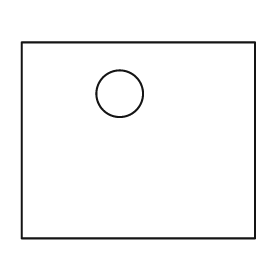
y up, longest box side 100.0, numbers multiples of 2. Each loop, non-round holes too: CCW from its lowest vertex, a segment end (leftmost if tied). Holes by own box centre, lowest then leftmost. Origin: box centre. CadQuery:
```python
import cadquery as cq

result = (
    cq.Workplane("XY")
    .moveTo(-50.0, -42.0)
    .lineTo(50.0, -42.0)
    .lineTo(50.0, 42.0)
    .lineTo(-50.0, 42.0)
    .close()
    .moveTo(-8.0, 20.0)
    .circle(10.0)
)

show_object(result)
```